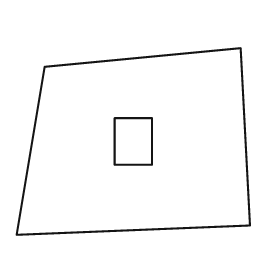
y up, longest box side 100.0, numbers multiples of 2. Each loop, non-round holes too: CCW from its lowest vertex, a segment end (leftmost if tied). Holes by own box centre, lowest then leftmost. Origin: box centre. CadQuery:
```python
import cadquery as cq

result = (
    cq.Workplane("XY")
    .moveTo(-50.0, -40.0)
    .lineTo(50.0, -36.0)
    .lineTo(46.0, 40.0)
    .lineTo(-38.0, 32.0)
    .close()
    .moveTo(-8.0, -10.0)
    .lineTo(8.0, -10.0)
    .lineTo(8.0, 10.0)
    .lineTo(-8.0, 10.0)
    .close()
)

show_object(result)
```